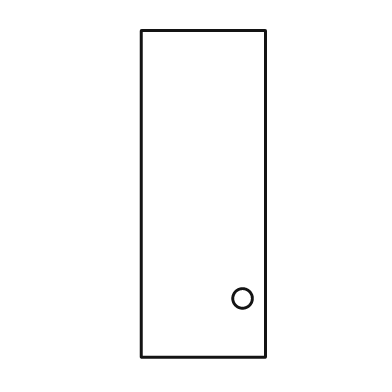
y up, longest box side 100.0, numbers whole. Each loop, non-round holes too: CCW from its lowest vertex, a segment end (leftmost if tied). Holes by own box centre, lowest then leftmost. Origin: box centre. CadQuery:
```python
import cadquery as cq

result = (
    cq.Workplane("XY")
    .moveTo(-19.0, -50.0)
    .lineTo(19.0, -50.0)
    .lineTo(19.0, 50.0)
    .lineTo(-19.0, 50.0)
    .close()
    .moveTo(12.0, -32.0)
    .circle(3.0)
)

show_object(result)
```